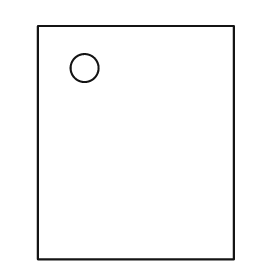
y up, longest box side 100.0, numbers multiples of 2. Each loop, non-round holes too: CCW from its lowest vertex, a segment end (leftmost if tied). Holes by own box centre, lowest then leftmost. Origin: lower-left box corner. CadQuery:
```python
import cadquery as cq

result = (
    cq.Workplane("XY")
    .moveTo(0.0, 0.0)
    .lineTo(84.0, 0.0)
    .lineTo(84.0, 100.0)
    .lineTo(0.0, 100.0)
    .close()
    .moveTo(20.0, 82.0)
    .circle(6.0)
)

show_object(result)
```